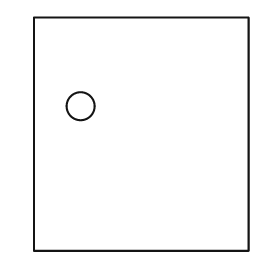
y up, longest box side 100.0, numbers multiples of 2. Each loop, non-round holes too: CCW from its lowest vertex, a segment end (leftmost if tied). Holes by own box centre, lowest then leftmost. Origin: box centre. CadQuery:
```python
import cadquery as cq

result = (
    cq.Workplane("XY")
    .moveTo(-46.0, -50.0)
    .lineTo(46.0, -50.0)
    .lineTo(46.0, 50.0)
    .lineTo(-46.0, 50.0)
    .close()
    .moveTo(-26.0, 12.0)
    .circle(6.0)
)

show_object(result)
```